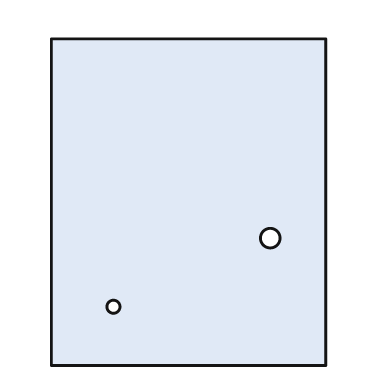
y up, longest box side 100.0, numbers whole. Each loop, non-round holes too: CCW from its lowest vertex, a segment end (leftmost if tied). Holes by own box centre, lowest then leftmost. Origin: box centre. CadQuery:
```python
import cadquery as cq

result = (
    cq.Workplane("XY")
    .moveTo(-42.0, -50.0)
    .lineTo(42.0, -50.0)
    .lineTo(42.0, 50.0)
    .lineTo(-42.0, 50.0)
    .close()
    .moveTo(-23.0, -32.0)
    .circle(2.0)
    .moveTo(25.0, -11.0)
    .circle(3.0)
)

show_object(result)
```